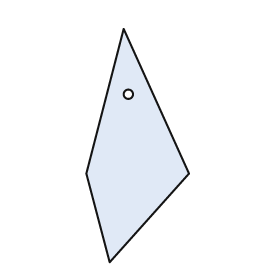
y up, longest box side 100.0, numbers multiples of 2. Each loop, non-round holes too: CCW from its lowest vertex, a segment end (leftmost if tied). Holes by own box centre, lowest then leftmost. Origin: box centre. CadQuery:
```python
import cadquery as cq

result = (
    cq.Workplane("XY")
    .moveTo(-12.0, -50.0)
    .lineTo(22.0, -12.0)
    .lineTo(-6.0, 50.0)
    .lineTo(-22.0, -12.0)
    .close()
    .moveTo(-4.0, 22.0)
    .circle(2.0)
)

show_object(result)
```